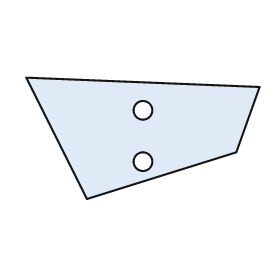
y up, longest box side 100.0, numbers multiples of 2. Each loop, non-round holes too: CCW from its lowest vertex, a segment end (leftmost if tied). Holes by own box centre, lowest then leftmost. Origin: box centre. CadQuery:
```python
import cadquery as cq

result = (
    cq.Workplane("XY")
    .moveTo(-24.0, -26.0)
    .lineTo(40.0, -6.0)
    .lineTo(50.0, 22.0)
    .lineTo(-50.0, 26.0)
    .close()
    .moveTo(0.0, -10.0)
    .circle(4.0)
    .moveTo(0.0, 12.0)
    .circle(4.0)
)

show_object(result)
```